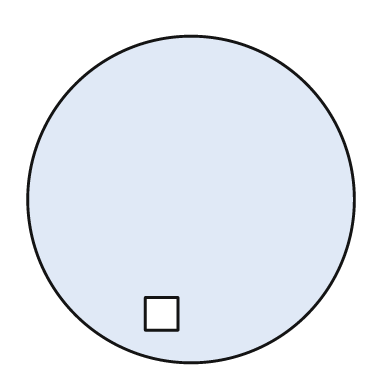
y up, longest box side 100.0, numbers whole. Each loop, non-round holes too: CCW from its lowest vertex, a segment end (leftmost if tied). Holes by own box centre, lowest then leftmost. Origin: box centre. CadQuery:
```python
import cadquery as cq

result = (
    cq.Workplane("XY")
    .moveTo(0.0, 0.0)
    .circle(50.0)
    .moveTo(-14.0, -40.0)
    .lineTo(-4.0, -40.0)
    .lineTo(-4.0, -30.0)
    .lineTo(-14.0, -30.0)
    .close()
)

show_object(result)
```